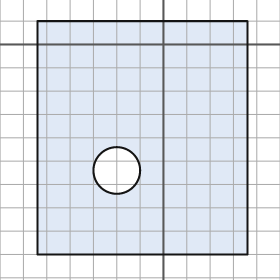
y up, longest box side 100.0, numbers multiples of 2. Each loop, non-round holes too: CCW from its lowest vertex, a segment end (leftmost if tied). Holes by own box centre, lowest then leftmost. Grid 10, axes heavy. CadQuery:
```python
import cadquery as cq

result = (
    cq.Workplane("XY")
    .moveTo(-54.0, -90.0)
    .lineTo(36.0, -90.0)
    .lineTo(36.0, 10.0)
    .lineTo(-54.0, 10.0)
    .close()
    .moveTo(-20.0, -54.0)
    .circle(10.0)
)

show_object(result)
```